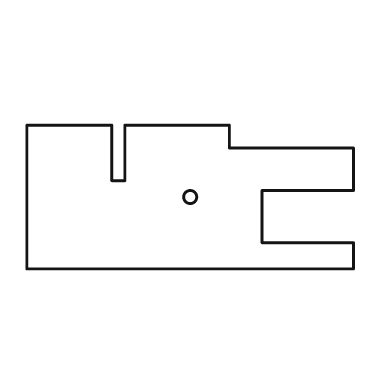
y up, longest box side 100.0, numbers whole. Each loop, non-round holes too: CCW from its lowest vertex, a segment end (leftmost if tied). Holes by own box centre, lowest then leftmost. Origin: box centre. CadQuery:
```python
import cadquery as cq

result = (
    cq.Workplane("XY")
    .moveTo(-50.0, -22.0)
    .lineTo(50.0, -22.0)
    .lineTo(50.0, -14.0)
    .lineTo(22.0, -14.0)
    .lineTo(22.0, 2.0)
    .lineTo(50.0, 2.0)
    .lineTo(50.0, 15.0)
    .lineTo(12.0, 15.0)
    .lineTo(12.0, 22.0)
    .lineTo(-20.0, 22.0)
    .lineTo(-20.0, 5.0)
    .lineTo(-24.0, 5.0)
    .lineTo(-24.0, 22.0)
    .lineTo(-50.0, 22.0)
    .close()
    .moveTo(0.0, 0.0)
    .circle(2.0)
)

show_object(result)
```